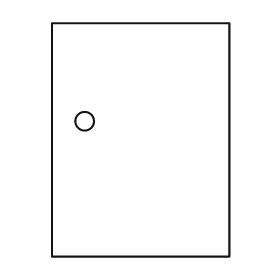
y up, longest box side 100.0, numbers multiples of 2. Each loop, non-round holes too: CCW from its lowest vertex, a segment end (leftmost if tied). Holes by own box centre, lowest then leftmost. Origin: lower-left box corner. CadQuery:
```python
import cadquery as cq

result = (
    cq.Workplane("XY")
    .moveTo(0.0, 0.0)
    .lineTo(76.0, 0.0)
    .lineTo(76.0, 100.0)
    .lineTo(0.0, 100.0)
    .close()
    .moveTo(14.0, 58.0)
    .circle(4.0)
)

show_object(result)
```